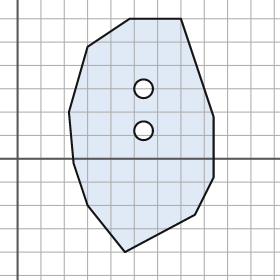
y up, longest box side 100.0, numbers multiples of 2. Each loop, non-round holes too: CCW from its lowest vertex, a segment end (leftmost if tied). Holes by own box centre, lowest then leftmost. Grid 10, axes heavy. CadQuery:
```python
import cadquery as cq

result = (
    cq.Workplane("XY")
    .moveTo(46.0, -40.0)
    .lineTo(76.0, -24.0)
    .lineTo(84.0, -8.0)
    .lineTo(84.0, 18.0)
    .lineTo(70.0, 60.0)
    .lineTo(48.0, 60.0)
    .lineTo(30.0, 48.0)
    .lineTo(22.0, 20.0)
    .lineTo(24.0, -2.0)
    .lineTo(30.0, -20.0)
    .close()
    .moveTo(54.0, 12.0)
    .circle(4.0)
    .moveTo(54.0, 30.0)
    .circle(4.0)
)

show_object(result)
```